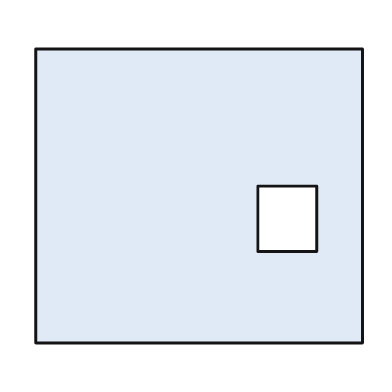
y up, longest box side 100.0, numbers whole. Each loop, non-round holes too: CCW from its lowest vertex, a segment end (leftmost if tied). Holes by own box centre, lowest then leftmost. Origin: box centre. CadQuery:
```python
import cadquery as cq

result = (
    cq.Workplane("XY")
    .moveTo(-50.0, -45.0)
    .lineTo(50.0, -45.0)
    .lineTo(50.0, 45.0)
    .lineTo(-50.0, 45.0)
    .close()
    .moveTo(18.0, -17.0)
    .lineTo(36.0, -17.0)
    .lineTo(36.0, 3.0)
    .lineTo(18.0, 3.0)
    .close()
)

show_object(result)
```